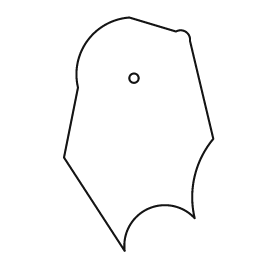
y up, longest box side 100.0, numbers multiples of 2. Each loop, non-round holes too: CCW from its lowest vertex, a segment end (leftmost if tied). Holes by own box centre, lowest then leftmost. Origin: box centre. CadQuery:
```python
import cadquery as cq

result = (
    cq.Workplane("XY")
    .moveTo(-6.0, -50.0)
    .threePointArc((4.0, -32.0), (24.0, -36.0))
    .threePointArc((24.0, -18.0), (32.0, -2.0))
    .lineTo(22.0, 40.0)
    .threePointArc((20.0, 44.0), (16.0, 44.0))
    .lineTo(-4.0, 50.0)
    .threePointArc((-22.0, 40.0), (-26.0, 20.0))
    .lineTo(-32.0, -10.0)
    .close()
    .moveTo(-2.0, 24.0)
    .circle(2.0)
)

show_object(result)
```